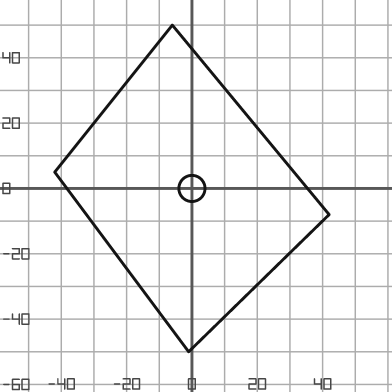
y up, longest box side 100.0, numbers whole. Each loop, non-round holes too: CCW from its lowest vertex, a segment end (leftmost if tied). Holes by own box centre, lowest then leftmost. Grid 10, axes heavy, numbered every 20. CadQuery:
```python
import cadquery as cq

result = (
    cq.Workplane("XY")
    .moveTo(-1.0, -50.0)
    .lineTo(42.0, -8.0)
    .lineTo(-6.0, 50.0)
    .lineTo(-42.0, 5.0)
    .close()
    .moveTo(0.0, 0.0)
    .circle(4.0)
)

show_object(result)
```